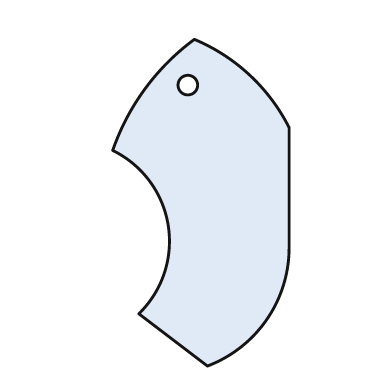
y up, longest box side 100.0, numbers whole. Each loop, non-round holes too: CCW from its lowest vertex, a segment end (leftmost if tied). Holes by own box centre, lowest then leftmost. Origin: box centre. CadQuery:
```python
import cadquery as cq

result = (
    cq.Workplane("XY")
    .moveTo(2.0, -50.0)
    .threePointArc((20.0, -36.0), (27.0, -14.0))
    .lineTo(27.0, 23.0)
    .threePointArc((15.0, 39.0), (-2.0, 50.0))
    .threePointArc((-17.0, 35.0), (-27.0, 16.0))
    .threePointArc((-10.0, -7.0), (-19.0, -34.0))
    .close()
    .moveTo(-4.0, 36.0)
    .circle(3.0)
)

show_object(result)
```